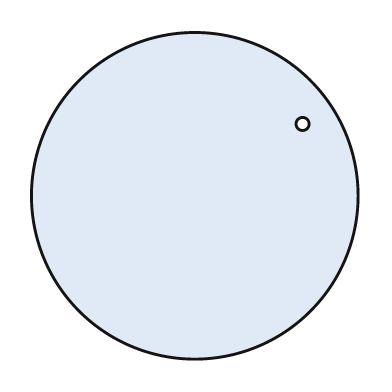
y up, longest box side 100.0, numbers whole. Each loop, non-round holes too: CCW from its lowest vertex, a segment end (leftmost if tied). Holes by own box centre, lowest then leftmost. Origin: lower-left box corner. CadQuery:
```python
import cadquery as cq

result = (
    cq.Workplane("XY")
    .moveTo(50.0, 50.0)
    .circle(50.0)
    .moveTo(83.0, 72.0)
    .circle(2.0)
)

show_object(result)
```